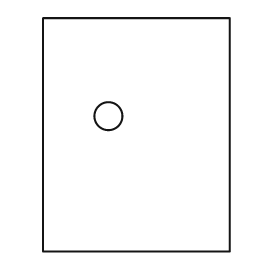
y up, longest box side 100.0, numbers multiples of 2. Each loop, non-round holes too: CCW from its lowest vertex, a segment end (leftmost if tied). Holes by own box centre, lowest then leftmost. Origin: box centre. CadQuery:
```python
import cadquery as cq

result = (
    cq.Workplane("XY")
    .moveTo(-40.0, -50.0)
    .lineTo(40.0, -50.0)
    .lineTo(40.0, 50.0)
    .lineTo(-40.0, 50.0)
    .close()
    .moveTo(-12.0, 8.0)
    .circle(6.0)
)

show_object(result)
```